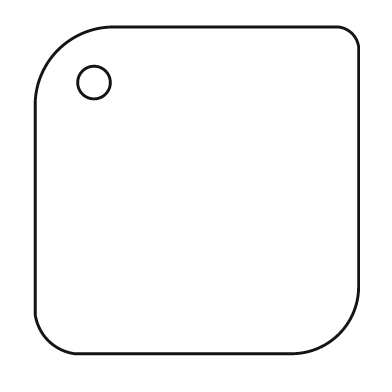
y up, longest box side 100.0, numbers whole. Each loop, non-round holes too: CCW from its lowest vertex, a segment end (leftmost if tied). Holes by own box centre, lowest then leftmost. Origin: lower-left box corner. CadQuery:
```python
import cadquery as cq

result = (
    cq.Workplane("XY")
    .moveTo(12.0, 0.0)
    .lineTo(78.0, 0.0)
    .threePointArc((93.0, 6.0), (99.0, 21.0))
    .lineTo(99.0, 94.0)
    .threePointArc((97.0, 98.0), (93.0, 100.0))
    .lineTo(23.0, 100.0)
    .threePointArc((7.0, 93.0), (0.0, 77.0))
    .lineTo(0.0, 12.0)
    .threePointArc((4.0, 4.0), (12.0, 0.0))
    .close()
    .moveTo(18.0, 83.0)
    .circle(5.0)
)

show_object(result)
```